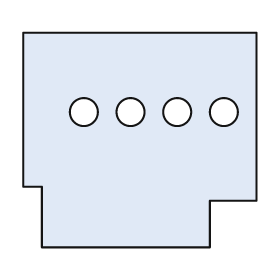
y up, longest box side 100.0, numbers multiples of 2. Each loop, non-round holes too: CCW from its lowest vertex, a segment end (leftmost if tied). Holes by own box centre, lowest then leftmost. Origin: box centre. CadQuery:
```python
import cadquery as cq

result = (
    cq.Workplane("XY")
    .moveTo(-42.0, -46.0)
    .lineTo(30.0, -46.0)
    .lineTo(30.0, -26.0)
    .lineTo(50.0, -26.0)
    .lineTo(50.0, 46.0)
    .lineTo(-50.0, 46.0)
    .lineTo(-50.0, -20.0)
    .lineTo(-42.0, -20.0)
    .close()
    .moveTo(-24.0, 12.0)
    .circle(6.0)
    .moveTo(-4.0, 12.0)
    .circle(6.0)
    .moveTo(16.0, 12.0)
    .circle(6.0)
    .moveTo(36.0, 12.0)
    .circle(6.0)
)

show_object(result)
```